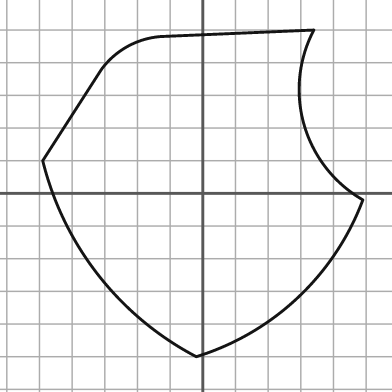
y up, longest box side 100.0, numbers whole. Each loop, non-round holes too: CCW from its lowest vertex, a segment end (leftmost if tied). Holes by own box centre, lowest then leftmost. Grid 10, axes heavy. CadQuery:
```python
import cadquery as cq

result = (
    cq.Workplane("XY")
    .moveTo(-2.0, -50.0)
    .threePointArc((29.0, -32.0), (49.0, -2.0))
    .threePointArc((31.0, 21.0), (34.0, 50.0))
    .lineTo(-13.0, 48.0)
    .threePointArc((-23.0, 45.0), (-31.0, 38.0))
    .lineTo(-49.0, 10.0)
    .threePointArc((-32.0, -25.0), (-2.0, -50.0))
    .close()
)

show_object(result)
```